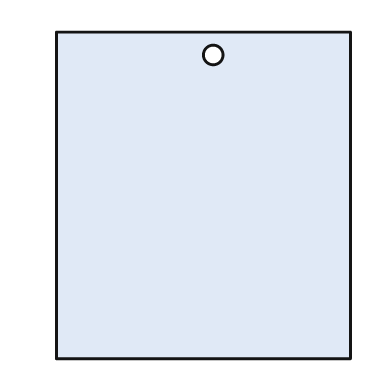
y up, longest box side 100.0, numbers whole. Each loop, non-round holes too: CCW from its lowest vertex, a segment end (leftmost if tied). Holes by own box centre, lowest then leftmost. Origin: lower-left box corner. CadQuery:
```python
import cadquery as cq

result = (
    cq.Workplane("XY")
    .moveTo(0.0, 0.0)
    .lineTo(90.0, 0.0)
    .lineTo(90.0, 100.0)
    .lineTo(0.0, 100.0)
    .close()
    .moveTo(48.0, 93.0)
    .circle(3.0)
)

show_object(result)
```